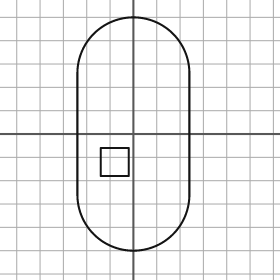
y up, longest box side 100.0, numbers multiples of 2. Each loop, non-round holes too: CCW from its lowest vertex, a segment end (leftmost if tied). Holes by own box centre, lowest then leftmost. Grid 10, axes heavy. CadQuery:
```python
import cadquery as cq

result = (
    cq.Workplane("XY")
    .moveTo(-24.0, -26.0)
    .threePointArc((0.0, -50.0), (24.0, -26.0))
    .lineTo(24.0, 26.0)
    .threePointArc((0.0, 50.0), (-24.0, 26.0))
    .close()
    .moveTo(-14.0, -18.0)
    .lineTo(-2.0, -18.0)
    .lineTo(-2.0, -6.0)
    .lineTo(-14.0, -6.0)
    .close()
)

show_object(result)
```